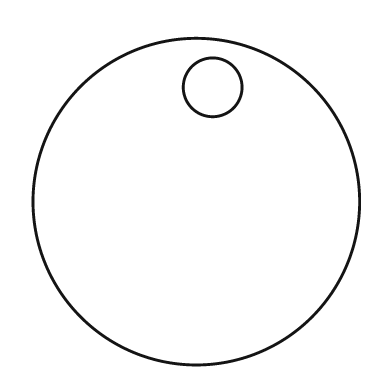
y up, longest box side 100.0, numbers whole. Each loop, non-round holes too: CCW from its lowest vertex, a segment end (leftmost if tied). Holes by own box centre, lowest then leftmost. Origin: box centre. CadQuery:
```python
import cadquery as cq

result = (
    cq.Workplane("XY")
    .moveTo(0.0, 0.0)
    .circle(50.0)
    .moveTo(5.0, 35.0)
    .circle(9.0)
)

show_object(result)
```